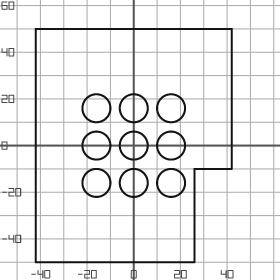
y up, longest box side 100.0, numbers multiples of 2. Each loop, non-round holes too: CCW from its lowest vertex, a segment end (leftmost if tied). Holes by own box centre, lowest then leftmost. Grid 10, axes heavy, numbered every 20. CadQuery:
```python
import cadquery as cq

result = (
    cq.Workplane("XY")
    .moveTo(-42.0, -50.0)
    .lineTo(26.0, -50.0)
    .lineTo(26.0, -10.0)
    .lineTo(42.0, -10.0)
    .lineTo(42.0, 50.0)
    .lineTo(-42.0, 50.0)
    .close()
    .moveTo(-16.0, -16.0)
    .circle(6.0)
    .moveTo(0.0, -16.0)
    .circle(6.0)
    .moveTo(16.0, -16.0)
    .circle(6.0)
    .moveTo(-16.0, 0.0)
    .circle(6.0)
    .moveTo(0.0, 0.0)
    .circle(6.0)
    .moveTo(16.0, 0.0)
    .circle(6.0)
    .moveTo(-16.0, 16.0)
    .circle(6.0)
    .moveTo(0.0, 16.0)
    .circle(6.0)
    .moveTo(16.0, 16.0)
    .circle(6.0)
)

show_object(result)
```